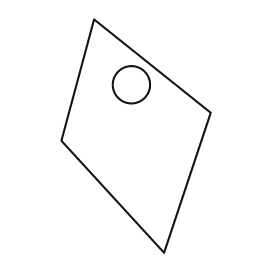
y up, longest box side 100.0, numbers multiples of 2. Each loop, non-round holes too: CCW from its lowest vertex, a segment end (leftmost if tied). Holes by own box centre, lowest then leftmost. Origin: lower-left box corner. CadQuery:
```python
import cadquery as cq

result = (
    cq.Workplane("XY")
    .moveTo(44.0, 0.0)
    .lineTo(64.0, 60.0)
    .lineTo(14.0, 100.0)
    .lineTo(0.0, 48.0)
    .close()
    .moveTo(30.0, 72.0)
    .circle(8.0)
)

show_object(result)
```